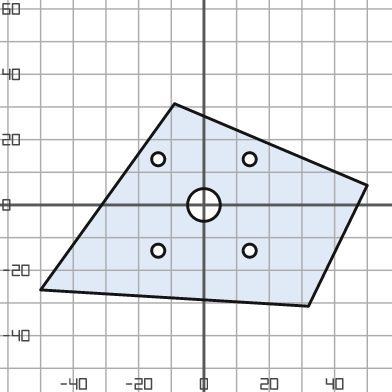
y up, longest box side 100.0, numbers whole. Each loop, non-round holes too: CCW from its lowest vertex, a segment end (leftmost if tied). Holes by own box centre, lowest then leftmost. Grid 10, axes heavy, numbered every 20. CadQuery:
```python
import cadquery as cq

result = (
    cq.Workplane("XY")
    .moveTo(32.0, -31.0)
    .lineTo(50.0, 6.0)
    .lineTo(-9.0, 31.0)
    .lineTo(-50.0, -26.0)
    .close()
    .moveTo(-14.0, -14.0)
    .circle(2.0)
    .moveTo(14.0, -14.0)
    .circle(2.0)
    .moveTo(0.0, 0.0)
    .circle(5.0)
    .moveTo(-14.0, 14.0)
    .circle(2.0)
    .moveTo(14.0, 14.0)
    .circle(2.0)
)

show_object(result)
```